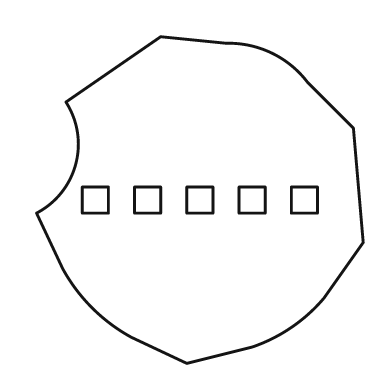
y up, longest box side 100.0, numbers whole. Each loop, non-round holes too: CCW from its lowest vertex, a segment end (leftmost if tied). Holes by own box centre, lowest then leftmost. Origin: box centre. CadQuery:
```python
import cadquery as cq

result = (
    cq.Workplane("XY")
    .moveTo(-4.0, -50.0)
    .lineTo(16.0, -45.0)
    .threePointArc((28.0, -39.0), (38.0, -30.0))
    .lineTo(50.0, -13.0)
    .lineTo(47.0, 22.0)
    .lineTo(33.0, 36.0)
    .threePointArc((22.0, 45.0), (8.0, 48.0))
    .lineTo(-12.0, 50.0)
    .lineTo(-41.0, 30.0)
    .threePointArc((-38.0, 11.0), (-50.0, -4.0))
    .lineTo(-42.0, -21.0)
    .threePointArc((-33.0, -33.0), (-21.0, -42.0))
    .close()
    .moveTo(-36.0, -4.0)
    .lineTo(-28.0, -4.0)
    .lineTo(-28.0, 4.0)
    .lineTo(-36.0, 4.0)
    .close()
    .moveTo(-20.0, -4.0)
    .lineTo(-12.0, -4.0)
    .lineTo(-12.0, 4.0)
    .lineTo(-20.0, 4.0)
    .close()
    .moveTo(-4.0, -4.0)
    .lineTo(4.0, -4.0)
    .lineTo(4.0, 4.0)
    .lineTo(-4.0, 4.0)
    .close()
    .moveTo(12.0, -4.0)
    .lineTo(20.0, -4.0)
    .lineTo(20.0, 4.0)
    .lineTo(12.0, 4.0)
    .close()
    .moveTo(28.0, -4.0)
    .lineTo(36.0, -4.0)
    .lineTo(36.0, 4.0)
    .lineTo(28.0, 4.0)
    .close()
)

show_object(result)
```